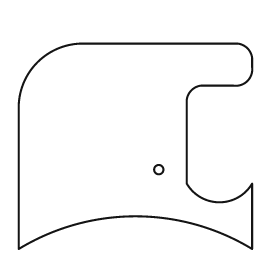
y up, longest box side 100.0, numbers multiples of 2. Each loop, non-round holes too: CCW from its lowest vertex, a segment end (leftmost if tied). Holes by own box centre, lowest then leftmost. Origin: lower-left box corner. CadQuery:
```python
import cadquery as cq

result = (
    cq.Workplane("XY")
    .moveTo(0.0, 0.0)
    .threePointArc((50.0, 14.0), (100.0, 0.0))
    .lineTo(100.0, 28.0)
    .threePointArc((86.0, 20.0), (72.0, 28.0))
    .lineTo(72.0, 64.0)
    .threePointArc((74.0, 68.0), (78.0, 70.0))
    .lineTo(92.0, 70.0)
    .threePointArc((98.0, 72.0), (100.0, 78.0))
    .lineTo(100.0, 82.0)
    .threePointArc((98.0, 86.0), (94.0, 88.0))
    .lineTo(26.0, 88.0)
    .threePointArc((8.0, 80.0), (0.0, 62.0))
    .close()
    .moveTo(60.0, 34.0)
    .circle(2.0)
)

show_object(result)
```